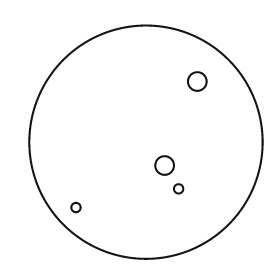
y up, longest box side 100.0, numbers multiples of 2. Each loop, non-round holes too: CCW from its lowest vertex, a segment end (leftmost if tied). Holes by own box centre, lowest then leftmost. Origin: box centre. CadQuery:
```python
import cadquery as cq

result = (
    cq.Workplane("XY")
    .moveTo(0.0, 0.0)
    .circle(50.0)
    .moveTo(-30.0, -28.0)
    .circle(2.0)
    .moveTo(14.0, -20.0)
    .circle(2.0)
    .moveTo(8.0, -10.0)
    .circle(4.0)
    .moveTo(22.0, 26.0)
    .circle(4.0)
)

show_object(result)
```